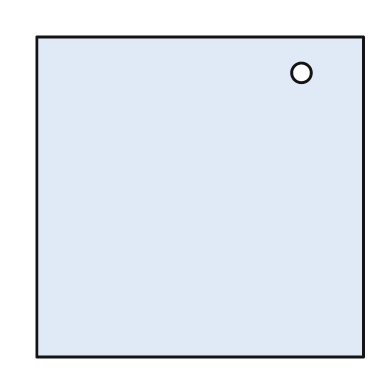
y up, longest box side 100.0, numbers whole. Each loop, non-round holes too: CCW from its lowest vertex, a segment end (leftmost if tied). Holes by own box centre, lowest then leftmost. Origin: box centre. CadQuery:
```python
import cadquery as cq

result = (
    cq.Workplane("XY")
    .moveTo(-50.0, -49.0)
    .lineTo(50.0, -49.0)
    .lineTo(50.0, 49.0)
    .lineTo(-50.0, 49.0)
    .close()
    .moveTo(31.0, 38.0)
    .circle(3.0)
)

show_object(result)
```